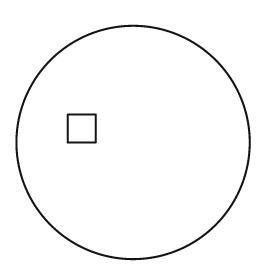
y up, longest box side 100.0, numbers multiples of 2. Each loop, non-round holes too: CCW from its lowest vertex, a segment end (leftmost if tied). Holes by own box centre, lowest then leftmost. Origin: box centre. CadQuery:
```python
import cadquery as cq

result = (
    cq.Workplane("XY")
    .moveTo(0.0, 0.0)
    .circle(50.0)
    .moveTo(-28.0, 0.0)
    .lineTo(-16.0, 0.0)
    .lineTo(-16.0, 12.0)
    .lineTo(-28.0, 12.0)
    .close()
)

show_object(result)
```